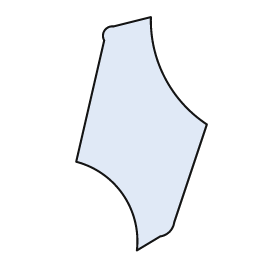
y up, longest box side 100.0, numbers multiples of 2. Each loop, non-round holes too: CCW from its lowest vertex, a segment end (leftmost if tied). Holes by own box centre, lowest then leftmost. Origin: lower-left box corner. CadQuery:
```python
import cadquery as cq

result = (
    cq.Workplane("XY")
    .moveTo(26.0, 0.0)
    .lineTo(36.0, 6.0)
    .threePointArc((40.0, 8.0), (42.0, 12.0))
    .lineTo(56.0, 54.0)
    .threePointArc((38.0, 74.0), (32.0, 100.0))
    .lineTo(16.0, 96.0)
    .threePointArc((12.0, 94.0), (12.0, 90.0))
    .lineTo(0.0, 38.0)
    .threePointArc((20.0, 24.0), (26.0, 0.0))
    .close()
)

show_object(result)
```